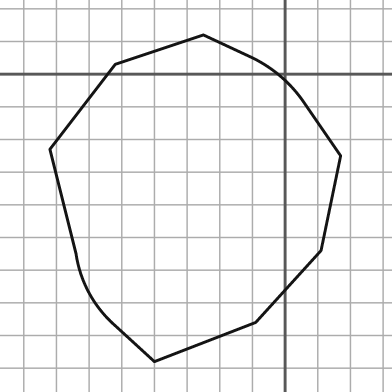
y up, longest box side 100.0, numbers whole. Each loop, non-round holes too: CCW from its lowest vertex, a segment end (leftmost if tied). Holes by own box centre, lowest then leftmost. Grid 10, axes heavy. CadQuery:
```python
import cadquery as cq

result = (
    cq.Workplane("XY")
    .moveTo(-40.0, -88.0)
    .lineTo(-9.0, -76.0)
    .lineTo(11.0, -54.0)
    .lineTo(17.0, -25.0)
    .lineTo(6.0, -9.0)
    .threePointArc((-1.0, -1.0), (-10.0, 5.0))
    .lineTo(-25.0, 12.0)
    .lineTo(-52.0, 3.0)
    .lineTo(-72.0, -23.0)
    .lineTo(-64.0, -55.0)
    .threePointArc((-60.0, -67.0), (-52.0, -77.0))
    .close()
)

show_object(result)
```